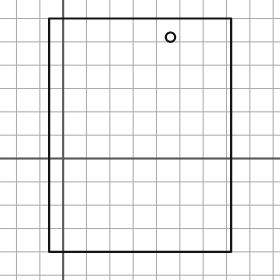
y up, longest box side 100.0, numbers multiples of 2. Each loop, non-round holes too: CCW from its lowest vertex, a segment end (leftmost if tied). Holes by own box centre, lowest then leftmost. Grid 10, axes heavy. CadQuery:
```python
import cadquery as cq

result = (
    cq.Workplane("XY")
    .moveTo(-6.0, -40.0)
    .lineTo(72.0, -40.0)
    .lineTo(72.0, 60.0)
    .lineTo(-6.0, 60.0)
    .close()
    .moveTo(46.0, 52.0)
    .circle(2.0)
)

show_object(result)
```